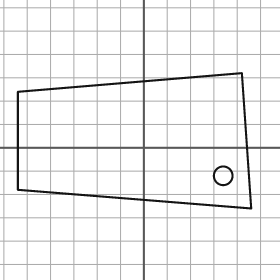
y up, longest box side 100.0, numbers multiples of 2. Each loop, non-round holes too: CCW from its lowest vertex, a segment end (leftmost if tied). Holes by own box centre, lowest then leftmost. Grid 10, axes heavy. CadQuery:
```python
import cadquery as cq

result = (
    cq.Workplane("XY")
    .moveTo(46.0, -26.0)
    .lineTo(42.0, 32.0)
    .lineTo(-54.0, 24.0)
    .lineTo(-54.0, -18.0)
    .close()
    .moveTo(34.0, -12.0)
    .circle(4.0)
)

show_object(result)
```